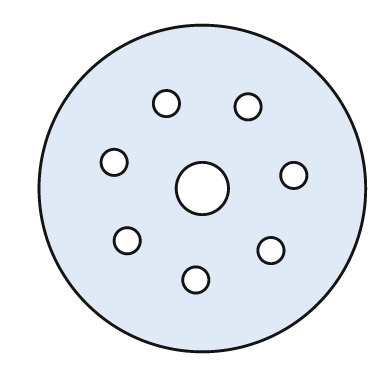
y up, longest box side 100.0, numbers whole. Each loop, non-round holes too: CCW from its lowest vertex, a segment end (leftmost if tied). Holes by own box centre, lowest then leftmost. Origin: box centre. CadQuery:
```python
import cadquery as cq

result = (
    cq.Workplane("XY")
    .moveTo(0.0, 0.0)
    .circle(50.0)
    .moveTo(-2.0, -28.0)
    .circle(4.0)
    .moveTo(21.0, -19.0)
    .circle(4.0)
    .moveTo(-23.0, -16.0)
    .circle(4.0)
    .moveTo(0.0, 0.0)
    .circle(8.0)
    .moveTo(28.0, 4.0)
    .circle(4.0)
    .moveTo(-27.0, 8.0)
    .circle(4.0)
    .moveTo(14.0, 25.0)
    .circle(4.0)
    .moveTo(-11.0, 26.0)
    .circle(4.0)
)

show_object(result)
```